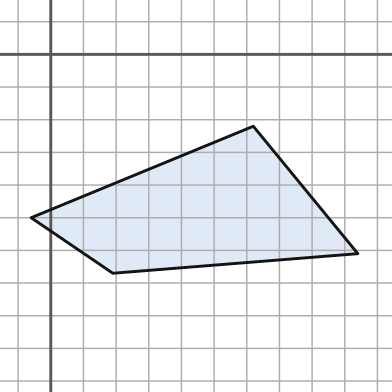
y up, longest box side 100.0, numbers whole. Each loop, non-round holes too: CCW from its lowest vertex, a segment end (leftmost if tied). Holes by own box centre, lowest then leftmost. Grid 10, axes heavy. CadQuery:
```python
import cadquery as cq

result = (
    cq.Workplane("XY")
    .moveTo(19.0, -67.0)
    .lineTo(94.0, -61.0)
    .lineTo(62.0, -22.0)
    .lineTo(-6.0, -50.0)
    .close()
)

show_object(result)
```